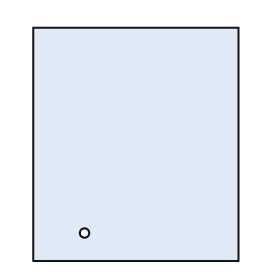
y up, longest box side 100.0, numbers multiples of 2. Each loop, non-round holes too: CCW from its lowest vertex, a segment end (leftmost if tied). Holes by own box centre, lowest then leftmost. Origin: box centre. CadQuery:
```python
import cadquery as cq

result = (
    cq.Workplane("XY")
    .moveTo(-44.0, -50.0)
    .lineTo(44.0, -50.0)
    .lineTo(44.0, 50.0)
    .lineTo(-44.0, 50.0)
    .close()
    .moveTo(-22.0, -38.0)
    .circle(2.0)
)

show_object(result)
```